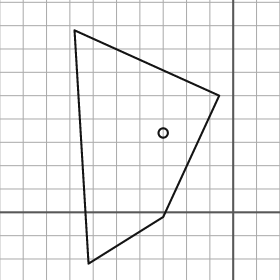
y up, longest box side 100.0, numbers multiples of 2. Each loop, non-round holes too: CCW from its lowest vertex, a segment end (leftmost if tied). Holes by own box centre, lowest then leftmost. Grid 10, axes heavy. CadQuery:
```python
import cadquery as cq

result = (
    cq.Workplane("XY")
    .moveTo(-62.0, -22.0)
    .lineTo(-30.0, -2.0)
    .lineTo(-6.0, 50.0)
    .lineTo(-68.0, 78.0)
    .close()
    .moveTo(-30.0, 34.0)
    .circle(2.0)
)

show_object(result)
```